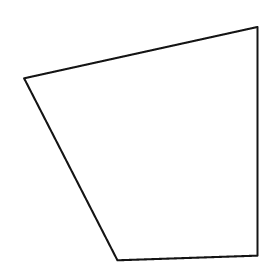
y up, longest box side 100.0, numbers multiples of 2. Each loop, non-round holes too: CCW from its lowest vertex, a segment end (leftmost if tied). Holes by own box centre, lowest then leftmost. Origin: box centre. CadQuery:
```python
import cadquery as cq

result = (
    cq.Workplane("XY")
    .moveTo(-10.0, -50.0)
    .lineTo(50.0, -48.0)
    .lineTo(50.0, 50.0)
    .lineTo(-50.0, 28.0)
    .close()
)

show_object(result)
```